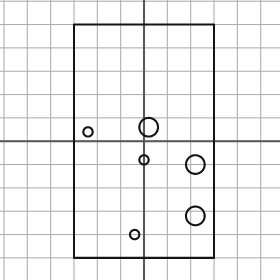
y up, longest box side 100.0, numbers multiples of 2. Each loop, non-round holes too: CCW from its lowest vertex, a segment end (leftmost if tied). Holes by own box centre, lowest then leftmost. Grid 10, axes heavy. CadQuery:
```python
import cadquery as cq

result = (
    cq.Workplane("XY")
    .moveTo(-30.0, -50.0)
    .lineTo(30.0, -50.0)
    .lineTo(30.0, 50.0)
    .lineTo(-30.0, 50.0)
    .close()
    .moveTo(-4.0, -40.0)
    .circle(2.0)
    .moveTo(22.0, -32.0)
    .circle(4.0)
    .moveTo(22.0, -10.0)
    .circle(4.0)
    .moveTo(0.0, -8.0)
    .circle(2.0)
    .moveTo(-24.0, 4.0)
    .circle(2.0)
    .moveTo(2.0, 6.0)
    .circle(4.0)
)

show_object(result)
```